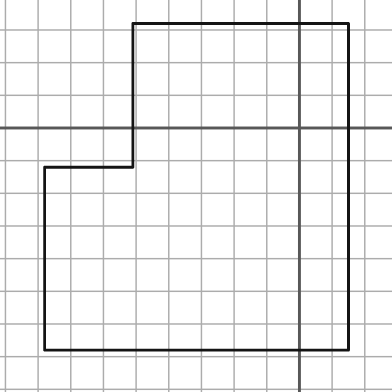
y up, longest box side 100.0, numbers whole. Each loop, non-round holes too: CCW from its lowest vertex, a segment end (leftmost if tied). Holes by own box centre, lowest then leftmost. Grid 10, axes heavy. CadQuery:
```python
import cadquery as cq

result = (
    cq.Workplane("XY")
    .moveTo(-78.0, -68.0)
    .lineTo(15.0, -68.0)
    .lineTo(15.0, 32.0)
    .lineTo(-51.0, 32.0)
    .lineTo(-51.0, -12.0)
    .lineTo(-78.0, -12.0)
    .close()
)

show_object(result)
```